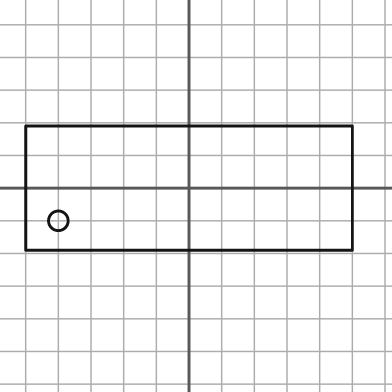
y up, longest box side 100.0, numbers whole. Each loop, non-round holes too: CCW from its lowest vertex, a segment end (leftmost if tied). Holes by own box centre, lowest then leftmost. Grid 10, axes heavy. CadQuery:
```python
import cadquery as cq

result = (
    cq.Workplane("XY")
    .moveTo(-50.0, -19.0)
    .lineTo(50.0, -19.0)
    .lineTo(50.0, 19.0)
    .lineTo(-50.0, 19.0)
    .close()
    .moveTo(-40.0, -10.0)
    .circle(3.0)
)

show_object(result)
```